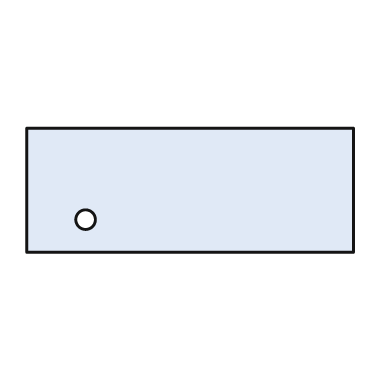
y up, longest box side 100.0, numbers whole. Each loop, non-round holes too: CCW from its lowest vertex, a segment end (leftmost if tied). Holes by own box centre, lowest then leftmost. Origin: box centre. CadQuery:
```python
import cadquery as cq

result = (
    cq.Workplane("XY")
    .moveTo(-50.0, -19.0)
    .lineTo(50.0, -19.0)
    .lineTo(50.0, 19.0)
    .lineTo(-50.0, 19.0)
    .close()
    .moveTo(-32.0, -9.0)
    .circle(3.0)
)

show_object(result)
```